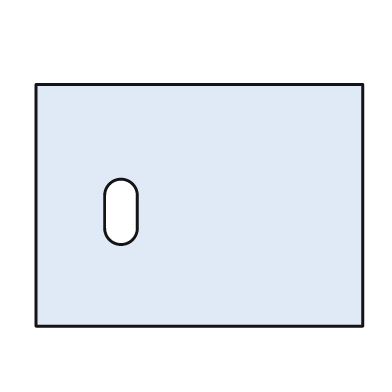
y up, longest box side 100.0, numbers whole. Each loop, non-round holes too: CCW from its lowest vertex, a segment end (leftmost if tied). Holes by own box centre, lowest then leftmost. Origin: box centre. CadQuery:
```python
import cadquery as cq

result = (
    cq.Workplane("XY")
    .moveTo(-50.0, -37.0)
    .lineTo(50.0, -37.0)
    .lineTo(50.0, 37.0)
    .lineTo(-50.0, 37.0)
    .close()
    .moveTo(-29.0, -7.0)
    .threePointArc((-24.0, -12.0), (-19.0, -7.0))
    .lineTo(-19.0, 3.0)
    .threePointArc((-24.0, 8.0), (-29.0, 3.0))
    .close()
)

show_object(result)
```